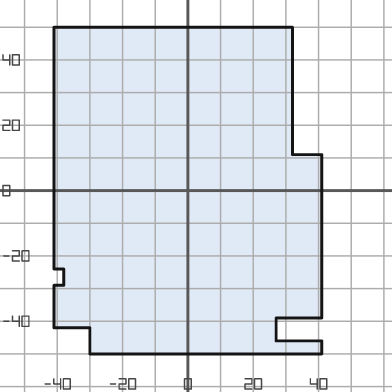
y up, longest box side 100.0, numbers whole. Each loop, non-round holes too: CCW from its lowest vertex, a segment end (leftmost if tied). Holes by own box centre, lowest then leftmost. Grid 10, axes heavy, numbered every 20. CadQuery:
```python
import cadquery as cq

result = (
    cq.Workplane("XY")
    .moveTo(-30.0, -50.0)
    .lineTo(41.0, -50.0)
    .lineTo(41.0, -46.0)
    .lineTo(27.0, -46.0)
    .lineTo(27.0, -39.0)
    .lineTo(41.0, -39.0)
    .lineTo(41.0, 11.0)
    .lineTo(32.0, 11.0)
    .lineTo(32.0, 50.0)
    .lineTo(-41.0, 50.0)
    .lineTo(-41.0, -24.0)
    .lineTo(-38.0, -24.0)
    .lineTo(-38.0, -29.0)
    .lineTo(-41.0, -29.0)
    .lineTo(-41.0, -42.0)
    .lineTo(-30.0, -42.0)
    .close()
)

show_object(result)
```